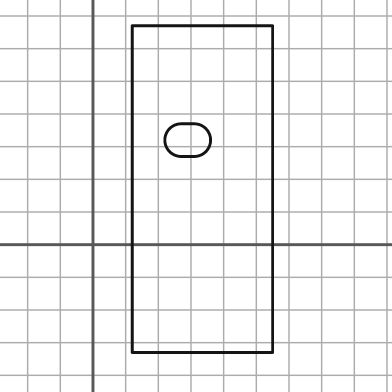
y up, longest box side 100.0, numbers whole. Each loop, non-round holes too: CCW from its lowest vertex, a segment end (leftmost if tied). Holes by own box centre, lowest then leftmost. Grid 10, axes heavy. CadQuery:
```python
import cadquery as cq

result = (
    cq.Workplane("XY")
    .moveTo(12.0, -33.0)
    .lineTo(55.0, -33.0)
    .lineTo(55.0, 67.0)
    .lineTo(12.0, 67.0)
    .close()
    .moveTo(27.0, 27.0)
    .lineTo(31.0, 27.0)
    .threePointArc((36.0, 32.0), (31.0, 37.0))
    .lineTo(27.0, 37.0)
    .threePointArc((22.0, 32.0), (27.0, 27.0))
    .close()
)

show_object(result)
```